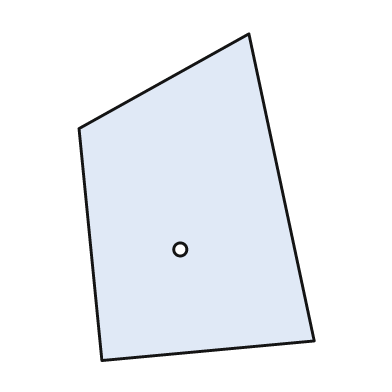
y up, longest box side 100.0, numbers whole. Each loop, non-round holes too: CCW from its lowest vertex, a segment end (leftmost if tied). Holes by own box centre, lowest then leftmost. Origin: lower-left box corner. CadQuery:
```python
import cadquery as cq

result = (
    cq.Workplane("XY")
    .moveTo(7.0, 0.0)
    .lineTo(72.0, 6.0)
    .lineTo(52.0, 100.0)
    .lineTo(0.0, 71.0)
    .close()
    .moveTo(31.0, 34.0)
    .circle(2.0)
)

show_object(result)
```